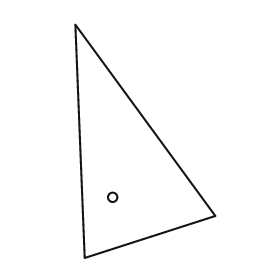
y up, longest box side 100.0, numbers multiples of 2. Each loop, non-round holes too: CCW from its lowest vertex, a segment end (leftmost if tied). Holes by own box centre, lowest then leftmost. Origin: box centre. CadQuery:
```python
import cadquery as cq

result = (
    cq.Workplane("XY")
    .moveTo(-26.0, -50.0)
    .lineTo(30.0, -32.0)
    .lineTo(-30.0, 50.0)
    .close()
    .moveTo(-14.0, -24.0)
    .circle(2.0)
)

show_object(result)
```